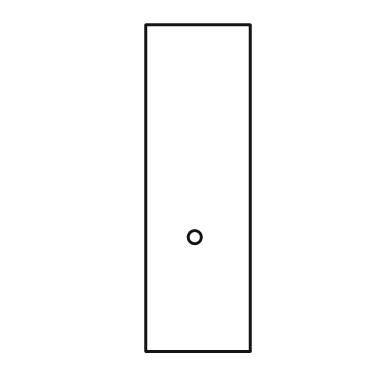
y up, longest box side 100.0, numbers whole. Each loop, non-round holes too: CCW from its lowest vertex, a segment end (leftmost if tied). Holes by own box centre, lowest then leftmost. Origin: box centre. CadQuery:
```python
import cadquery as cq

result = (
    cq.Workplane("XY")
    .moveTo(-16.0, -50.0)
    .lineTo(16.0, -50.0)
    .lineTo(16.0, 50.0)
    .lineTo(-16.0, 50.0)
    .close()
    .moveTo(-1.0, -15.0)
    .circle(2.0)
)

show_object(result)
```